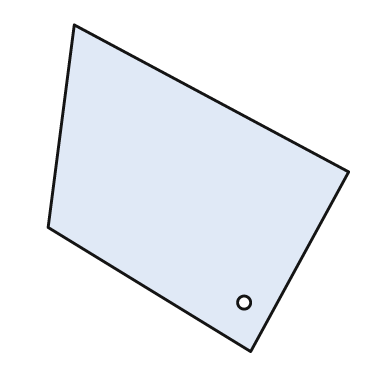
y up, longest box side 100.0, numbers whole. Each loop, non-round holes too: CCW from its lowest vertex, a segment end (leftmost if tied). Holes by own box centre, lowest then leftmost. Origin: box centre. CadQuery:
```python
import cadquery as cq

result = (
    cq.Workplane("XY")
    .moveTo(16.0, -50.0)
    .lineTo(46.0, 5.0)
    .lineTo(-38.0, 50.0)
    .lineTo(-46.0, -12.0)
    .close()
    .moveTo(14.0, -35.0)
    .circle(2.0)
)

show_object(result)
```